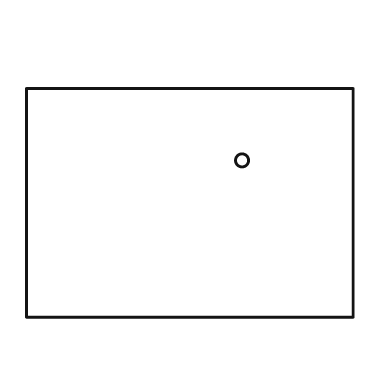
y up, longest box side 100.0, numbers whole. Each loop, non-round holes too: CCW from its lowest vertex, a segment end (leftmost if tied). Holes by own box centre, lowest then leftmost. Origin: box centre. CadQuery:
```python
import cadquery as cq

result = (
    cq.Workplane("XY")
    .moveTo(-50.0, -35.0)
    .lineTo(50.0, -35.0)
    .lineTo(50.0, 35.0)
    .lineTo(-50.0, 35.0)
    .close()
    .moveTo(16.0, 13.0)
    .circle(2.0)
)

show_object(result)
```